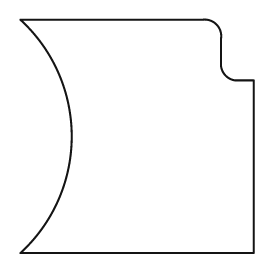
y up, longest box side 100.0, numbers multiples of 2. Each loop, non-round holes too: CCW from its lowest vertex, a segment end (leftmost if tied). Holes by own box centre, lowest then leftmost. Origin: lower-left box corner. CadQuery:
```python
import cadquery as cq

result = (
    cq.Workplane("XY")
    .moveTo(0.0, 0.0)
    .lineTo(100.0, 0.0)
    .lineTo(100.0, 74.0)
    .lineTo(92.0, 74.0)
    .threePointArc((88.0, 76.0), (86.0, 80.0))
    .lineTo(86.0, 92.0)
    .threePointArc((84.0, 98.0), (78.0, 100.0))
    .lineTo(0.0, 100.0)
    .threePointArc((22.0, 50.0), (0.0, 0.0))
    .close()
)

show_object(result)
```